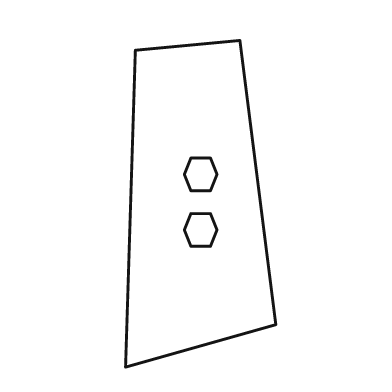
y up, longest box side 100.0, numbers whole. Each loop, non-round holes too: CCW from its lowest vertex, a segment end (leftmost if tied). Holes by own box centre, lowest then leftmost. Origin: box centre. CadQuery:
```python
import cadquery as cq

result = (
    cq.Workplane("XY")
    .moveTo(-23.0, -50.0)
    .lineTo(23.0, -37.0)
    .lineTo(12.0, 50.0)
    .lineTo(-20.0, 47.0)
    .close()
    .moveTo(-3.0, -13.0)
    .lineTo(3.0, -13.0)
    .lineTo(5.0, -8.0)
    .lineTo(3.0, -3.0)
    .lineTo(-3.0, -3.0)
    .lineTo(-5.0, -8.0)
    .close()
    .moveTo(-3.0, 4.0)
    .lineTo(3.0, 4.0)
    .lineTo(5.0, 9.0)
    .lineTo(3.0, 14.0)
    .lineTo(-3.0, 14.0)
    .lineTo(-5.0, 9.0)
    .close()
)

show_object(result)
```